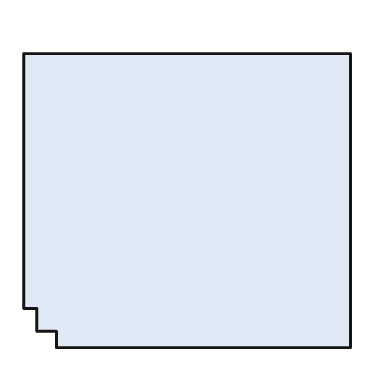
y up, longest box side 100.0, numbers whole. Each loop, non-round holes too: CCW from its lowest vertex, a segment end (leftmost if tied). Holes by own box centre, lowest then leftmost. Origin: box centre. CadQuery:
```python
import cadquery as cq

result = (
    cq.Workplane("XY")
    .moveTo(-40.0, -45.0)
    .lineTo(50.0, -45.0)
    .lineTo(50.0, 45.0)
    .lineTo(-50.0, 45.0)
    .lineTo(-50.0, -33.0)
    .lineTo(-46.0, -33.0)
    .lineTo(-46.0, -40.0)
    .lineTo(-40.0, -40.0)
    .close()
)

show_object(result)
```